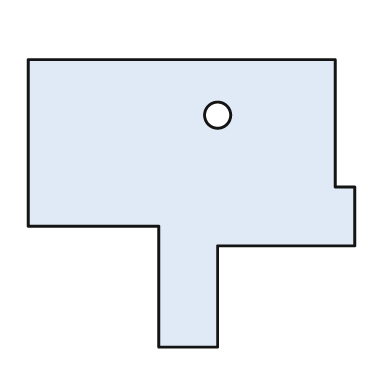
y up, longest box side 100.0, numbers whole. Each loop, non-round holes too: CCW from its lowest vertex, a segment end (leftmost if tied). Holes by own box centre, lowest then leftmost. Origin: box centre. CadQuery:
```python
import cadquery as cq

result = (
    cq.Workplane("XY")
    .moveTo(-10.0, -44.0)
    .lineTo(8.0, -44.0)
    .lineTo(8.0, -13.0)
    .lineTo(50.0, -13.0)
    .lineTo(50.0, 5.0)
    .lineTo(44.0, 5.0)
    .lineTo(44.0, 44.0)
    .lineTo(-50.0, 44.0)
    .lineTo(-50.0, -7.0)
    .lineTo(-10.0, -7.0)
    .close()
    .moveTo(8.0, 27.0)
    .circle(4.0)
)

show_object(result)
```